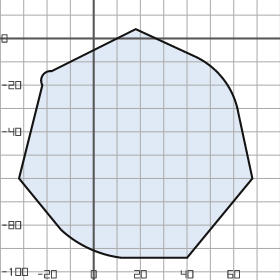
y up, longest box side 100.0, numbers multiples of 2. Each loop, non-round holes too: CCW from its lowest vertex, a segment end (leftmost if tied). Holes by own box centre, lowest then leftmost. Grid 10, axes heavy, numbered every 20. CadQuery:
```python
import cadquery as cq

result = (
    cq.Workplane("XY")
    .moveTo(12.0, -94.0)
    .lineTo(40.0, -94.0)
    .lineTo(68.0, -60.0)
    .lineTo(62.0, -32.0)
    .threePointArc((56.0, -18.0), (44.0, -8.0))
    .lineTo(18.0, 4.0)
    .lineTo(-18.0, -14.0)
    .threePointArc((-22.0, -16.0), (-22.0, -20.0))
    .lineTo(-32.0, -60.0)
    .lineTo(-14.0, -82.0)
    .threePointArc((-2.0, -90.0), (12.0, -94.0))
    .close()
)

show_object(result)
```